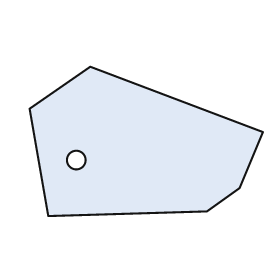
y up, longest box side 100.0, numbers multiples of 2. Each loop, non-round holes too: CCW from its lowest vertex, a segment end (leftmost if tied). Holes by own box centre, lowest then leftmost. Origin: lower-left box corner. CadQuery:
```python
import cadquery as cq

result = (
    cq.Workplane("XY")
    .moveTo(8.0, 0.0)
    .lineTo(76.0, 2.0)
    .lineTo(90.0, 12.0)
    .lineTo(100.0, 36.0)
    .lineTo(26.0, 64.0)
    .lineTo(0.0, 46.0)
    .close()
    .moveTo(20.0, 24.0)
    .circle(4.0)
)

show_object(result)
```